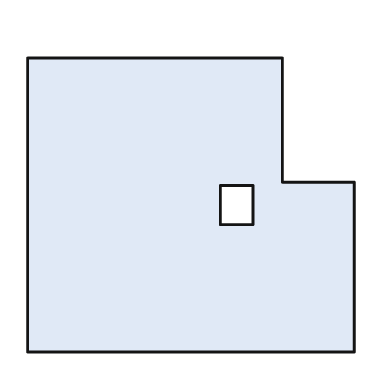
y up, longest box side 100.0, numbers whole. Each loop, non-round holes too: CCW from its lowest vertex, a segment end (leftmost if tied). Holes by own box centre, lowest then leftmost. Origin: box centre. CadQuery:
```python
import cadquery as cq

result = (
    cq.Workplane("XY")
    .moveTo(-50.0, -45.0)
    .lineTo(50.0, -45.0)
    .lineTo(50.0, 7.0)
    .lineTo(28.0, 7.0)
    .lineTo(28.0, 45.0)
    .lineTo(-50.0, 45.0)
    .close()
    .moveTo(9.0, -6.0)
    .lineTo(19.0, -6.0)
    .lineTo(19.0, 6.0)
    .lineTo(9.0, 6.0)
    .close()
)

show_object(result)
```